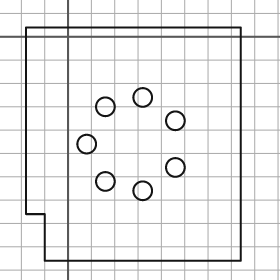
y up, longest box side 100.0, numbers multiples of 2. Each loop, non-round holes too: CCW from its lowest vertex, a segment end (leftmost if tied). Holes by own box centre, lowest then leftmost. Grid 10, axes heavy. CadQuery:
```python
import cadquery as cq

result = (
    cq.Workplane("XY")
    .moveTo(-10.0, -96.0)
    .lineTo(74.0, -96.0)
    .lineTo(74.0, 4.0)
    .lineTo(-18.0, 4.0)
    .lineTo(-18.0, -76.0)
    .lineTo(-10.0, -76.0)
    .close()
    .moveTo(32.0, -66.0)
    .circle(4.0)
    .moveTo(16.0, -62.0)
    .circle(4.0)
    .moveTo(46.0, -56.0)
    .circle(4.0)
    .moveTo(8.0, -46.0)
    .circle(4.0)
    .moveTo(46.0, -36.0)
    .circle(4.0)
    .moveTo(16.0, -30.0)
    .circle(4.0)
    .moveTo(32.0, -26.0)
    .circle(4.0)
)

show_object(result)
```